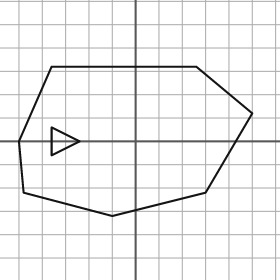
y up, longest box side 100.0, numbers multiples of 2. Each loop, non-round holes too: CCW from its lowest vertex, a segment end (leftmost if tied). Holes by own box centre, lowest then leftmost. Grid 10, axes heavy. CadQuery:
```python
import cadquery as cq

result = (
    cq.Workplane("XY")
    .moveTo(-10.0, -32.0)
    .lineTo(30.0, -22.0)
    .lineTo(50.0, 12.0)
    .lineTo(26.0, 32.0)
    .lineTo(-36.0, 32.0)
    .lineTo(-50.0, 0.0)
    .lineTo(-48.0, -22.0)
    .close()
    .moveTo(-36.0, -6.0)
    .lineTo(-24.0, 0.0)
    .lineTo(-36.0, 6.0)
    .close()
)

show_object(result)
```